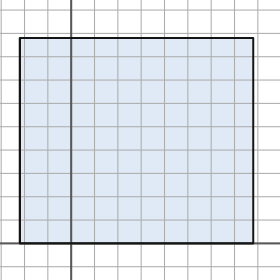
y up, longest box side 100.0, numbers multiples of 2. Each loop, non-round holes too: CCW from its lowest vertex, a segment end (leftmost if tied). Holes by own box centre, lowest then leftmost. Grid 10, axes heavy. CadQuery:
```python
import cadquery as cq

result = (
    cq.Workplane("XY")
    .moveTo(-22.0, 0.0)
    .lineTo(78.0, 0.0)
    .lineTo(78.0, 88.0)
    .lineTo(-22.0, 88.0)
    .close()
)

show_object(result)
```